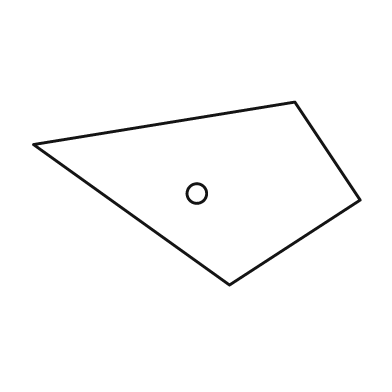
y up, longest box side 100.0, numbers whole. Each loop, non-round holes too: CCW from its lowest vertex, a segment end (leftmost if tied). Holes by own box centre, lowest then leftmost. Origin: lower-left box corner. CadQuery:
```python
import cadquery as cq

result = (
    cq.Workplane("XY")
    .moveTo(60.0, 0.0)
    .lineTo(100.0, 26.0)
    .lineTo(80.0, 56.0)
    .lineTo(0.0, 43.0)
    .close()
    .moveTo(50.0, 28.0)
    .circle(3.0)
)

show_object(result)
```